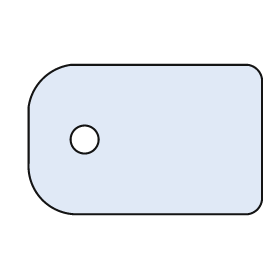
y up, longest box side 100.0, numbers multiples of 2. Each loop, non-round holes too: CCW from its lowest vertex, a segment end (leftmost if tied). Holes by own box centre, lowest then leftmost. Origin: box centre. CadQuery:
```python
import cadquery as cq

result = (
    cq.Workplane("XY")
    .moveTo(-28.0, -32.0)
    .lineTo(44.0, -32.0)
    .threePointArc((48.0, -30.0), (50.0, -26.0))
    .lineTo(50.0, 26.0)
    .threePointArc((48.0, 30.0), (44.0, 32.0))
    .lineTo(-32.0, 32.0)
    .threePointArc((-44.0, 26.0), (-50.0, 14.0))
    .lineTo(-50.0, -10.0)
    .threePointArc((-44.0, -26.0), (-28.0, -32.0))
    .close()
    .moveTo(-26.0, 0.0)
    .circle(6.0)
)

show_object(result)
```